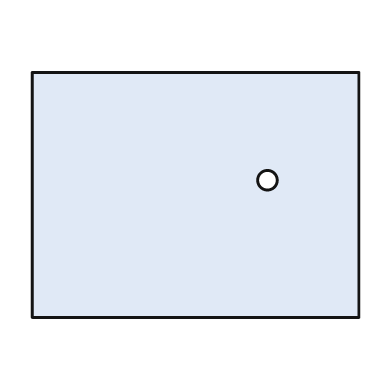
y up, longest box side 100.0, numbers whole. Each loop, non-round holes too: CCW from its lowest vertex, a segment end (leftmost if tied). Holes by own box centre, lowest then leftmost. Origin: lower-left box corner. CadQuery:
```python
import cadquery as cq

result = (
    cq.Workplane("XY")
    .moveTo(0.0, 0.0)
    .lineTo(100.0, 0.0)
    .lineTo(100.0, 75.0)
    .lineTo(0.0, 75.0)
    .close()
    .moveTo(72.0, 42.0)
    .circle(3.0)
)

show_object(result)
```